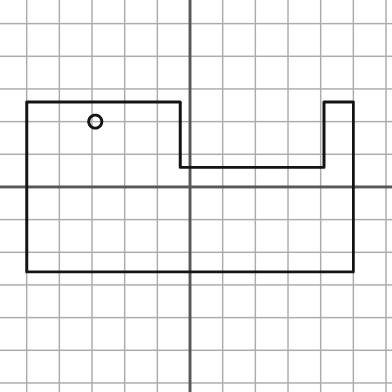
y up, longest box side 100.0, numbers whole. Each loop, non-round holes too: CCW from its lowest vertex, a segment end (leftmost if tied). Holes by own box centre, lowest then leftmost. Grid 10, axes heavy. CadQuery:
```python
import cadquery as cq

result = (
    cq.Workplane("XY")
    .moveTo(-50.0, -26.0)
    .lineTo(50.0, -26.0)
    .lineTo(50.0, 26.0)
    .lineTo(41.0, 26.0)
    .lineTo(41.0, 6.0)
    .lineTo(-3.0, 6.0)
    .lineTo(-3.0, 26.0)
    .lineTo(-50.0, 26.0)
    .close()
    .moveTo(-29.0, 20.0)
    .circle(2.0)
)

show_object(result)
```